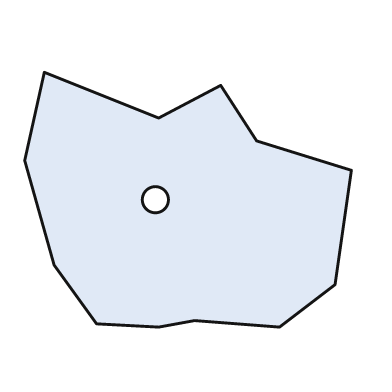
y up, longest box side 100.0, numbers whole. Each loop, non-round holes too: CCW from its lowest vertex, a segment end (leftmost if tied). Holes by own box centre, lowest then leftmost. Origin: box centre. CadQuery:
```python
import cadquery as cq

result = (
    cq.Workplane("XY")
    .moveTo(-9.0, -39.0)
    .lineTo(2.0, -37.0)
    .lineTo(28.0, -39.0)
    .lineTo(45.0, -26.0)
    .lineTo(50.0, 9.0)
    .lineTo(21.0, 18.0)
    .lineTo(10.0, 35.0)
    .lineTo(-9.0, 25.0)
    .lineTo(-44.0, 39.0)
    .lineTo(-50.0, 12.0)
    .lineTo(-41.0, -20.0)
    .lineTo(-28.0, -38.0)
    .close()
    .moveTo(-10.0, 0.0)
    .circle(4.0)
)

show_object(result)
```